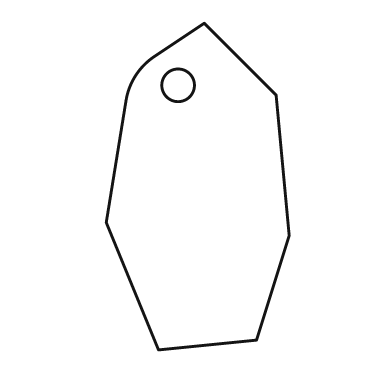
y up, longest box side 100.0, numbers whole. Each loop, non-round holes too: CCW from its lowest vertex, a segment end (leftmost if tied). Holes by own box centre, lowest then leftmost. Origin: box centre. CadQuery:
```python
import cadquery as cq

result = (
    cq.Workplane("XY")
    .moveTo(-12.0, -50.0)
    .lineTo(18.0, -47.0)
    .lineTo(28.0, -15.0)
    .lineTo(24.0, 28.0)
    .lineTo(2.0, 50.0)
    .lineTo(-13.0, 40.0)
    .threePointArc((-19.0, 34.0), (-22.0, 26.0))
    .lineTo(-28.0, -11.0)
    .close()
    .moveTo(-6.0, 31.0)
    .circle(5.0)
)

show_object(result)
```